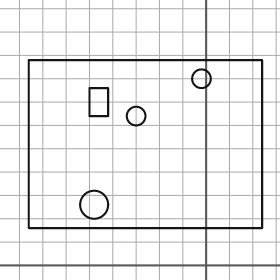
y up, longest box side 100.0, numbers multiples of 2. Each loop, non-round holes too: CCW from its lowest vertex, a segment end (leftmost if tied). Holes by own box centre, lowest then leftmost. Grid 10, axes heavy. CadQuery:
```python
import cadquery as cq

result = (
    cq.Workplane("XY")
    .moveTo(-76.0, 16.0)
    .lineTo(24.0, 16.0)
    .lineTo(24.0, 88.0)
    .lineTo(-76.0, 88.0)
    .close()
    .moveTo(-48.0, 26.0)
    .circle(6.0)
    .moveTo(-30.0, 64.0)
    .circle(4.0)
    .moveTo(-50.0, 64.0)
    .lineTo(-42.0, 64.0)
    .lineTo(-42.0, 76.0)
    .lineTo(-50.0, 76.0)
    .close()
    .moveTo(-2.0, 80.0)
    .circle(4.0)
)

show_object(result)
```